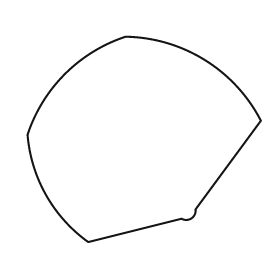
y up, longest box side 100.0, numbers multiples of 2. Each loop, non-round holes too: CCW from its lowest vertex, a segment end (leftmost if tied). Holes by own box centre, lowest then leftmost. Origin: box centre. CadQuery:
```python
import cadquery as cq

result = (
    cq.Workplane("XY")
    .moveTo(-24.0, -44.0)
    .lineTo(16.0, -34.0)
    .threePointArc((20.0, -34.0), (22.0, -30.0))
    .lineTo(50.0, 8.0)
    .threePointArc((26.0, 34.0), (-8.0, 44.0))
    .threePointArc((-34.0, 28.0), (-50.0, 2.0))
    .threePointArc((-42.0, -24.0), (-24.0, -44.0))
    .close()
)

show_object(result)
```